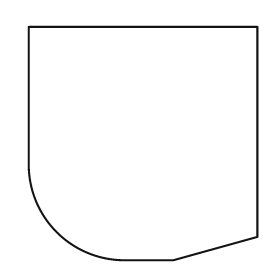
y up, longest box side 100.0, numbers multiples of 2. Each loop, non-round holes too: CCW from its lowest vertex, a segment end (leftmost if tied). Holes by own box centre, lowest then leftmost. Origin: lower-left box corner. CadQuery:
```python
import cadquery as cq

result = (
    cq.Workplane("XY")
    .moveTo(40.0, 0.0)
    .lineTo(62.0, 0.0)
    .lineTo(98.0, 10.0)
    .lineTo(98.0, 100.0)
    .lineTo(0.0, 100.0)
    .lineTo(0.0, 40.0)
    .threePointArc((12.0, 12.0), (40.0, 0.0))
    .close()
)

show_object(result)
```